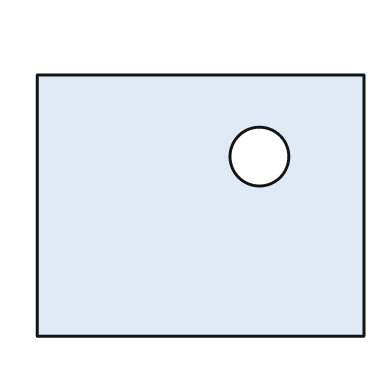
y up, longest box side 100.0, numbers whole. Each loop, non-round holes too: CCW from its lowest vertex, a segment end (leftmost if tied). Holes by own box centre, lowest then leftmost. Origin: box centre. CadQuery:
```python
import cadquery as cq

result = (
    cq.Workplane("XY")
    .moveTo(-50.0, -40.0)
    .lineTo(50.0, -40.0)
    .lineTo(50.0, 40.0)
    .lineTo(-50.0, 40.0)
    .close()
    .moveTo(18.0, 15.0)
    .circle(9.0)
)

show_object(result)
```